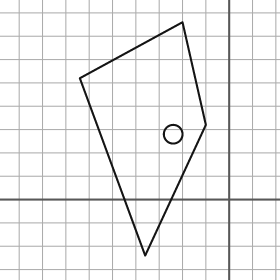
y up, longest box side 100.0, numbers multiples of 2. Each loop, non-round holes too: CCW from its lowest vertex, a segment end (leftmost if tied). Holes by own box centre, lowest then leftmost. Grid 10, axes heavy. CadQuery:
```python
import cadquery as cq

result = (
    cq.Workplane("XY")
    .moveTo(-36.0, -24.0)
    .lineTo(-10.0, 32.0)
    .lineTo(-20.0, 76.0)
    .lineTo(-64.0, 52.0)
    .close()
    .moveTo(-24.0, 28.0)
    .circle(4.0)
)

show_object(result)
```